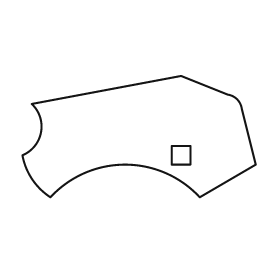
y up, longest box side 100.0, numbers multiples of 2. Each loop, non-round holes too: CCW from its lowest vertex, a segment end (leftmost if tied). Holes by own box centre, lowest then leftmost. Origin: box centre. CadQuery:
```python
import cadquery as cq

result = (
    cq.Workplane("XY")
    .moveTo(-38.0, -26.0)
    .threePointArc((-6.0, -12.0), (26.0, -26.0))
    .lineTo(50.0, -12.0)
    .lineTo(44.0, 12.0)
    .threePointArc((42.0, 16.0), (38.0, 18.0))
    .lineTo(18.0, 26.0)
    .lineTo(-46.0, 14.0)
    .threePointArc((-42.0, 2.0), (-50.0, -8.0))
    .threePointArc((-46.0, -18.0), (-38.0, -26.0))
    .close()
    .moveTo(14.0, -12.0)
    .lineTo(22.0, -12.0)
    .lineTo(22.0, -4.0)
    .lineTo(14.0, -4.0)
    .close()
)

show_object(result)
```